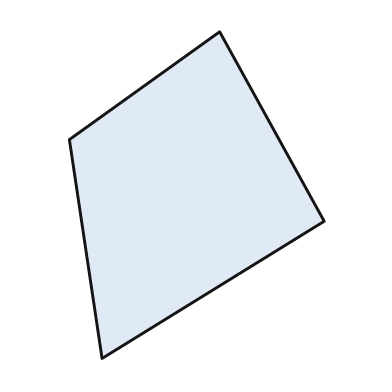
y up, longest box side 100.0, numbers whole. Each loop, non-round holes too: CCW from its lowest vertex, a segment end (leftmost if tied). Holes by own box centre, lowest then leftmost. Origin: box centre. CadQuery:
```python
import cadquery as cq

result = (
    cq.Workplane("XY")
    .moveTo(-29.0, -50.0)
    .lineTo(39.0, -8.0)
    .lineTo(7.0, 50.0)
    .lineTo(-39.0, 17.0)
    .close()
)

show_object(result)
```